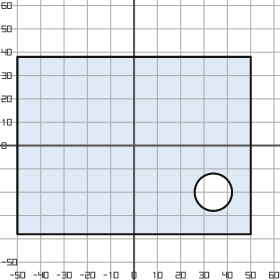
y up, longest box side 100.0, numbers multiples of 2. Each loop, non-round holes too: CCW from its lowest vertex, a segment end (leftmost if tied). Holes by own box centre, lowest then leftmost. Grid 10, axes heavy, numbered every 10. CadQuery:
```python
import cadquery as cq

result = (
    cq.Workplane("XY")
    .moveTo(-50.0, -38.0)
    .lineTo(50.0, -38.0)
    .lineTo(50.0, 38.0)
    .lineTo(-50.0, 38.0)
    .close()
    .moveTo(34.0, -20.0)
    .circle(8.0)
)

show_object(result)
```